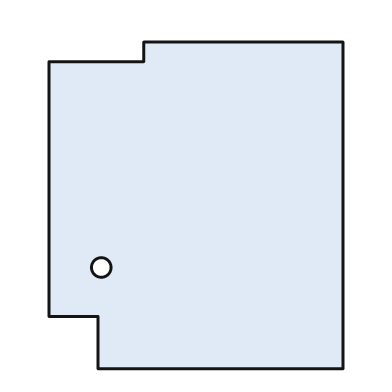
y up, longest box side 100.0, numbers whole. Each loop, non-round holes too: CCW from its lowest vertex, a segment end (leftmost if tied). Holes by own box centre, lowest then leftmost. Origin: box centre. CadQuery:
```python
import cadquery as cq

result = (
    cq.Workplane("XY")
    .moveTo(-30.0, -50.0)
    .lineTo(45.0, -50.0)
    .lineTo(45.0, 50.0)
    .lineTo(-16.0, 50.0)
    .lineTo(-16.0, 44.0)
    .lineTo(-45.0, 44.0)
    .lineTo(-45.0, -34.0)
    .lineTo(-30.0, -34.0)
    .close()
    .moveTo(-29.0, -19.0)
    .circle(3.0)
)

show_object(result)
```